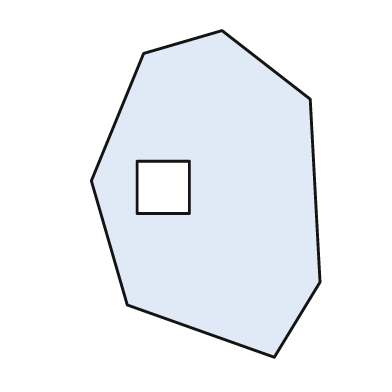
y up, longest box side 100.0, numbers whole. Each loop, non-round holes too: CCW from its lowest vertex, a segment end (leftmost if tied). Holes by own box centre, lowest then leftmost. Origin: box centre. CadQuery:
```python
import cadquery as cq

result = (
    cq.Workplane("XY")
    .moveTo(21.0, -50.0)
    .lineTo(35.0, -27.0)
    .lineTo(32.0, 29.0)
    .lineTo(5.0, 50.0)
    .lineTo(-19.0, 43.0)
    .lineTo(-35.0, 4.0)
    .lineTo(-24.0, -34.0)
    .close()
    .moveTo(-21.0, -6.0)
    .lineTo(-5.0, -6.0)
    .lineTo(-5.0, 10.0)
    .lineTo(-21.0, 10.0)
    .close()
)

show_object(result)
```